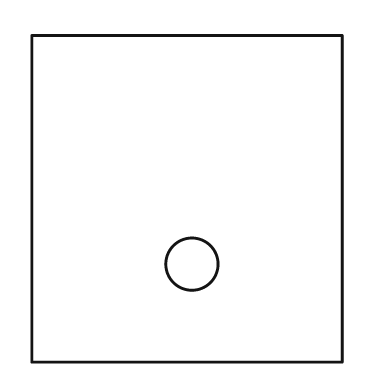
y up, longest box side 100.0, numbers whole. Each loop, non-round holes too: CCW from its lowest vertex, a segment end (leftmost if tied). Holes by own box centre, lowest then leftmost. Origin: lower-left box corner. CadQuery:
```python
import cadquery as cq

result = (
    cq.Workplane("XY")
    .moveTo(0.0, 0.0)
    .lineTo(95.0, 0.0)
    .lineTo(95.0, 100.0)
    .lineTo(0.0, 100.0)
    .close()
    .moveTo(49.0, 30.0)
    .circle(8.0)
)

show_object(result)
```